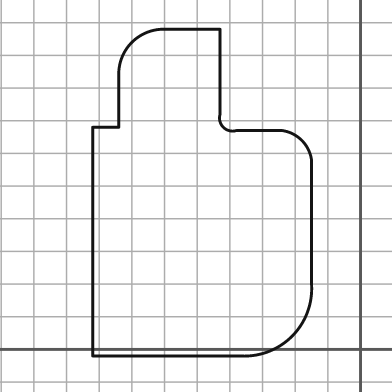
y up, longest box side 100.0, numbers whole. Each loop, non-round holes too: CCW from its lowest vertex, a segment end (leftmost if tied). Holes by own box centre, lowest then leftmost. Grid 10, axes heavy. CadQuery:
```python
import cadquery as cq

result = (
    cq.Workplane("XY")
    .moveTo(-82.0, -2.0)
    .lineTo(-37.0, -2.0)
    .threePointArc((-21.0, 4.0), (-15.0, 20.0))
    .lineTo(-15.0, 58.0)
    .threePointArc((-18.0, 64.0), (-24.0, 67.0))
    .lineTo(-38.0, 67.0)
    .threePointArc((-42.0, 68.0), (-43.0, 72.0))
    .lineTo(-43.0, 98.0)
    .lineTo(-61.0, 98.0)
    .threePointArc((-70.0, 94.0), (-74.0, 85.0))
    .lineTo(-74.0, 68.0)
    .lineTo(-82.0, 68.0)
    .close()
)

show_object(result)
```